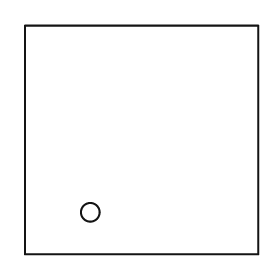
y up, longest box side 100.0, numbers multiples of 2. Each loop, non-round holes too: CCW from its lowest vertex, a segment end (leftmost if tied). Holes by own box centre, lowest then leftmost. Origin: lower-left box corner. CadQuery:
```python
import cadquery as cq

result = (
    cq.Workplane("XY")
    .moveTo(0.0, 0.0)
    .lineTo(100.0, 0.0)
    .lineTo(100.0, 98.0)
    .lineTo(0.0, 98.0)
    .close()
    .moveTo(28.0, 18.0)
    .circle(4.0)
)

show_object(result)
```